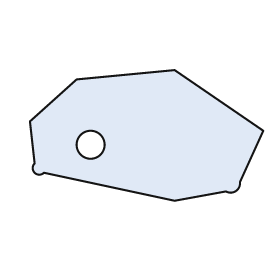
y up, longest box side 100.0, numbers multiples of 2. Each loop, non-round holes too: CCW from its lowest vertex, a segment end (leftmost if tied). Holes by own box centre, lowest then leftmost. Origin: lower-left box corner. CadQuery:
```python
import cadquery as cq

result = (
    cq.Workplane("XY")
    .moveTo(62.0, 0.0)
    .lineTo(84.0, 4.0)
    .threePointArc((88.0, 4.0), (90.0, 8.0))
    .lineTo(100.0, 30.0)
    .lineTo(62.0, 56.0)
    .lineTo(20.0, 52.0)
    .lineTo(0.0, 34.0)
    .lineTo(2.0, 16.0)
    .threePointArc((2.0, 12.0), (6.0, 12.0))
    .close()
    .moveTo(26.0, 24.0)
    .circle(6.0)
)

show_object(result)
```